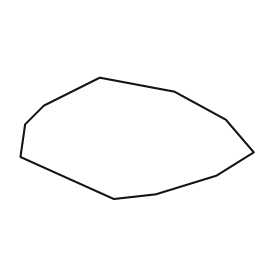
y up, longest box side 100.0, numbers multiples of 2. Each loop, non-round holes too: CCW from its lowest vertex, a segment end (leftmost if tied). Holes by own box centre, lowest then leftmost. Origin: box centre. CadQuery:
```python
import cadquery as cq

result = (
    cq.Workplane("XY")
    .moveTo(-10.0, -26.0)
    .lineTo(8.0, -24.0)
    .lineTo(34.0, -16.0)
    .lineTo(50.0, -6.0)
    .lineTo(38.0, 8.0)
    .lineTo(16.0, 20.0)
    .lineTo(-16.0, 26.0)
    .lineTo(-40.0, 14.0)
    .lineTo(-48.0, 6.0)
    .lineTo(-50.0, -8.0)
    .close()
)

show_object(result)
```